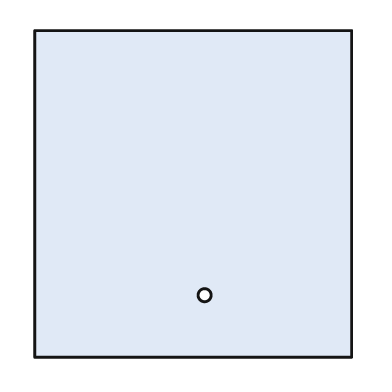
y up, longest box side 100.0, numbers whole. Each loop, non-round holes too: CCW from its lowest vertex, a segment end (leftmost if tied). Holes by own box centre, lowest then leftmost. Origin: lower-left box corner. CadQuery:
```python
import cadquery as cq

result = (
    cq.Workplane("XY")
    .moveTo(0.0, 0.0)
    .lineTo(97.0, 0.0)
    .lineTo(97.0, 100.0)
    .lineTo(0.0, 100.0)
    .close()
    .moveTo(52.0, 19.0)
    .circle(2.0)
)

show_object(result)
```